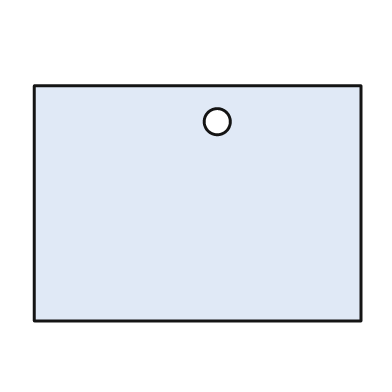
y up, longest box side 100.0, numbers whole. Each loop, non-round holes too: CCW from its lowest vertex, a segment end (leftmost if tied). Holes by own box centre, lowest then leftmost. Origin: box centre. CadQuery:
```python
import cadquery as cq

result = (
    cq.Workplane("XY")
    .moveTo(-50.0, -36.0)
    .lineTo(50.0, -36.0)
    .lineTo(50.0, 36.0)
    .lineTo(-50.0, 36.0)
    .close()
    .moveTo(6.0, 25.0)
    .circle(4.0)
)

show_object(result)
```